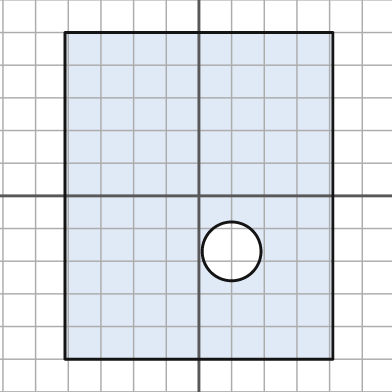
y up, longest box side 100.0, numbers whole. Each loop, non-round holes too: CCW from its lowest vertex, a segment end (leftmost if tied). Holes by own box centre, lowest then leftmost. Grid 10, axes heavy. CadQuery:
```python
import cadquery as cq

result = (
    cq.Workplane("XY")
    .moveTo(-41.0, -50.0)
    .lineTo(41.0, -50.0)
    .lineTo(41.0, 50.0)
    .lineTo(-41.0, 50.0)
    .close()
    .moveTo(10.0, -17.0)
    .circle(9.0)
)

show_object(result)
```